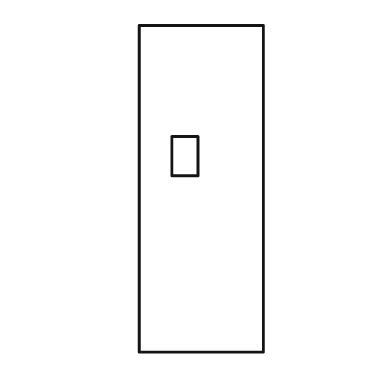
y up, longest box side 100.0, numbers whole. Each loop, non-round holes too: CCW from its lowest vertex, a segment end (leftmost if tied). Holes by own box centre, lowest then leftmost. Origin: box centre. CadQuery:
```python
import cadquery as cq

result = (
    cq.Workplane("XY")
    .moveTo(-19.0, -50.0)
    .lineTo(19.0, -50.0)
    .lineTo(19.0, 50.0)
    .lineTo(-19.0, 50.0)
    .close()
    .moveTo(-9.0, 4.0)
    .lineTo(-1.0, 4.0)
    .lineTo(-1.0, 16.0)
    .lineTo(-9.0, 16.0)
    .close()
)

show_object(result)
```